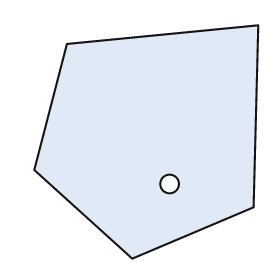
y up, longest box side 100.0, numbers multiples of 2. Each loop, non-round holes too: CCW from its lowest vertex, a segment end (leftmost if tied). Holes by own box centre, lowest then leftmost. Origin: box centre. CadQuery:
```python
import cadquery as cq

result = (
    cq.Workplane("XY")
    .moveTo(-6.0, -50.0)
    .lineTo(46.0, -28.0)
    .lineTo(48.0, 50.0)
    .lineTo(-34.0, 42.0)
    .lineTo(-48.0, -12.0)
    .close()
    .moveTo(10.0, -18.0)
    .circle(4.0)
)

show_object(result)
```